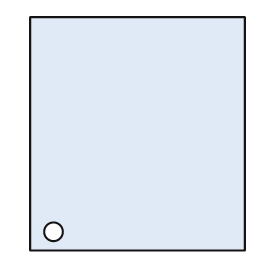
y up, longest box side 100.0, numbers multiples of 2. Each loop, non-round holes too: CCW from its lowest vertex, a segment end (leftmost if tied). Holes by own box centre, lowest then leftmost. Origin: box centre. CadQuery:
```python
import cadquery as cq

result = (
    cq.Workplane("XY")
    .moveTo(-46.0, -50.0)
    .lineTo(46.0, -50.0)
    .lineTo(46.0, 50.0)
    .lineTo(-46.0, 50.0)
    .close()
    .moveTo(-36.0, -42.0)
    .circle(4.0)
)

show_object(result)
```